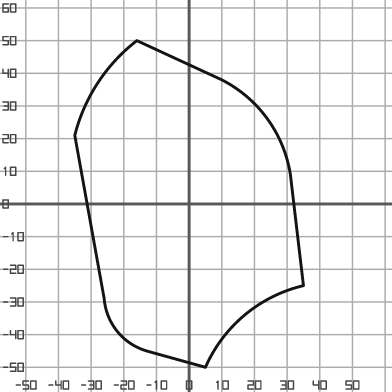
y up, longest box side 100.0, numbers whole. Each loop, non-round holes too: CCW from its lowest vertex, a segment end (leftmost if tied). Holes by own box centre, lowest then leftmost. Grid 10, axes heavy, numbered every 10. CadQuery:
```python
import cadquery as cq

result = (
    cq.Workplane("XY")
    .moveTo(5.0, -50.0)
    .threePointArc((17.0, -34.0), (35.0, -25.0))
    .lineTo(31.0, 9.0)
    .threePointArc((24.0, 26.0), (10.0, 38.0))
    .lineTo(-16.0, 50.0)
    .threePointArc((-28.0, 37.0), (-35.0, 21.0))
    .lineTo(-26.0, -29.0)
    .threePointArc((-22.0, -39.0), (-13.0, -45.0))
    .close()
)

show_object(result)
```